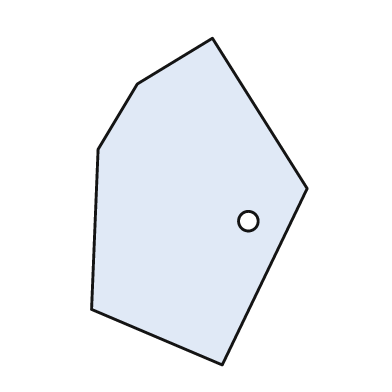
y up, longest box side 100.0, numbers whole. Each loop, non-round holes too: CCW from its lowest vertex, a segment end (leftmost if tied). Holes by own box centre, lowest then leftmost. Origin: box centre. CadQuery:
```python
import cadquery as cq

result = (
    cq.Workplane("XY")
    .moveTo(7.0, -50.0)
    .lineTo(33.0, 4.0)
    .lineTo(4.0, 50.0)
    .lineTo(-19.0, 36.0)
    .lineTo(-31.0, 16.0)
    .lineTo(-33.0, -33.0)
    .close()
    .moveTo(15.0, -6.0)
    .circle(3.0)
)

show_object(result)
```